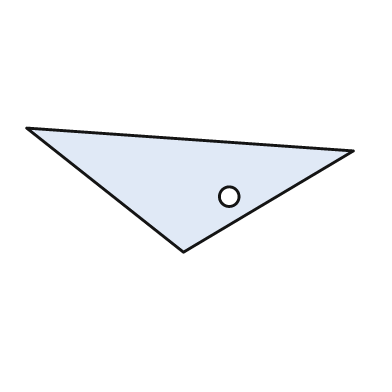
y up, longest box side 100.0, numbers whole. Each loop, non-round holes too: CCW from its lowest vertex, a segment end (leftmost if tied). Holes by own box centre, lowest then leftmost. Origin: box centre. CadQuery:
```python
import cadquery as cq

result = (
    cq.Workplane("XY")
    .moveTo(-2.0, -19.0)
    .lineTo(50.0, 12.0)
    .lineTo(-50.0, 19.0)
    .close()
    .moveTo(12.0, -2.0)
    .circle(3.0)
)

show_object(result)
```